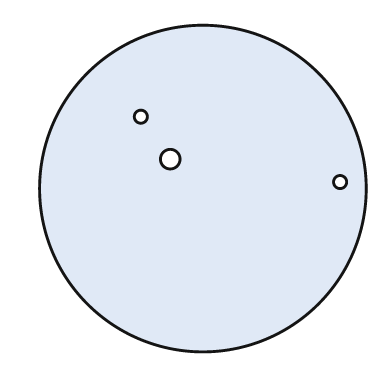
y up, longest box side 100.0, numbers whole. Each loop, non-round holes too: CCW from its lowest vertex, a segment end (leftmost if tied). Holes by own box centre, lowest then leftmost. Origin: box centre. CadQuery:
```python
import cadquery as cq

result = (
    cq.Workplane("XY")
    .moveTo(0.0, 0.0)
    .circle(50.0)
    .moveTo(42.0, 2.0)
    .circle(2.0)
    .moveTo(-10.0, 9.0)
    .circle(3.0)
    .moveTo(-19.0, 22.0)
    .circle(2.0)
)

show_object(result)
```